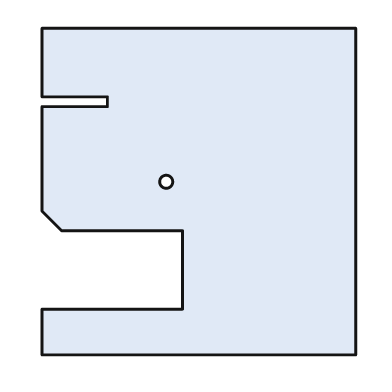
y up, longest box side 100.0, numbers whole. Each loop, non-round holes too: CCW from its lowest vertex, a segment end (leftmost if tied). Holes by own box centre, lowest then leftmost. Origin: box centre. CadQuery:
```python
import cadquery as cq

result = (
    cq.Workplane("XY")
    .moveTo(-48.0, -50.0)
    .lineTo(48.0, -50.0)
    .lineTo(48.0, 50.0)
    .lineTo(-48.0, 50.0)
    .lineTo(-48.0, 29.0)
    .lineTo(-28.0, 29.0)
    .lineTo(-28.0, 26.0)
    .lineTo(-48.0, 26.0)
    .lineTo(-48.0, -6.0)
    .lineTo(-42.0, -12.0)
    .lineTo(-5.0, -12.0)
    .lineTo(-5.0, -36.0)
    .lineTo(-48.0, -36.0)
    .close()
    .moveTo(-10.0, 3.0)
    .circle(2.0)
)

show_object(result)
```